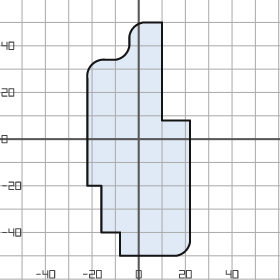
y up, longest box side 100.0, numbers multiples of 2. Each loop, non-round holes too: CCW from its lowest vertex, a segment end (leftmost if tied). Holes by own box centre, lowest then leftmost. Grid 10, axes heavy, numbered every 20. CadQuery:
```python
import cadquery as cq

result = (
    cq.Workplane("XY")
    .moveTo(-8.0, -50.0)
    .lineTo(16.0, -50.0)
    .threePointArc((20.0, -48.0), (22.0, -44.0))
    .lineTo(22.0, 8.0)
    .lineTo(10.0, 8.0)
    .lineTo(10.0, 50.0)
    .lineTo(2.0, 50.0)
    .threePointArc((-2.0, 48.0), (-4.0, 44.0))
    .lineTo(-4.0, 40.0)
    .threePointArc((-6.0, 36.0), (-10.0, 34.0))
    .lineTo(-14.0, 34.0)
    .threePointArc((-20.0, 32.0), (-22.0, 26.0))
    .lineTo(-22.0, -20.0)
    .lineTo(-16.0, -20.0)
    .lineTo(-16.0, -40.0)
    .lineTo(-8.0, -40.0)
    .close()
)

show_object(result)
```